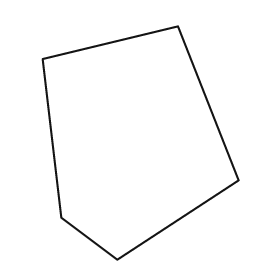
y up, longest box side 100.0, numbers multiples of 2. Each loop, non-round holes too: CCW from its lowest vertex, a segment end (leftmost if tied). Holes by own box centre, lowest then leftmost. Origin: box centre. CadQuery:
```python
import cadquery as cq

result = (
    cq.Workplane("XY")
    .moveTo(-10.0, -50.0)
    .lineTo(42.0, -16.0)
    .lineTo(16.0, 50.0)
    .lineTo(-42.0, 36.0)
    .lineTo(-34.0, -32.0)
    .close()
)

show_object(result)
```